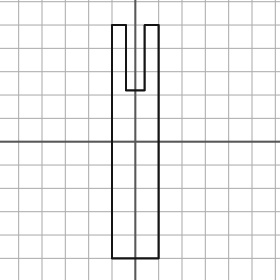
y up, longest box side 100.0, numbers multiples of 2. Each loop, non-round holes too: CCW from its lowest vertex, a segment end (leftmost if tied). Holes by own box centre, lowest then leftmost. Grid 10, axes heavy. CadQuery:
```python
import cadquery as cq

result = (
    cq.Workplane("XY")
    .moveTo(-10.0, -50.0)
    .lineTo(10.0, -50.0)
    .lineTo(10.0, 50.0)
    .lineTo(4.0, 50.0)
    .lineTo(4.0, 22.0)
    .lineTo(-4.0, 22.0)
    .lineTo(-4.0, 50.0)
    .lineTo(-10.0, 50.0)
    .close()
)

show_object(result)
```